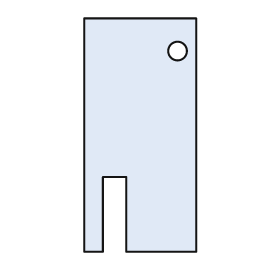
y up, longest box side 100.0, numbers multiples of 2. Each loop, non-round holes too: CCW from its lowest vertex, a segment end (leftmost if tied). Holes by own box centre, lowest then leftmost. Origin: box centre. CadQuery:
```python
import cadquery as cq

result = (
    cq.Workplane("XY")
    .moveTo(-24.0, -50.0)
    .lineTo(-16.0, -50.0)
    .lineTo(-16.0, -18.0)
    .lineTo(-6.0, -18.0)
    .lineTo(-6.0, -50.0)
    .lineTo(24.0, -50.0)
    .lineTo(24.0, 50.0)
    .lineTo(-24.0, 50.0)
    .close()
    .moveTo(16.0, 36.0)
    .circle(4.0)
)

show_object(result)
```